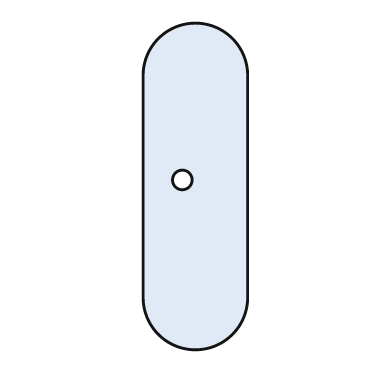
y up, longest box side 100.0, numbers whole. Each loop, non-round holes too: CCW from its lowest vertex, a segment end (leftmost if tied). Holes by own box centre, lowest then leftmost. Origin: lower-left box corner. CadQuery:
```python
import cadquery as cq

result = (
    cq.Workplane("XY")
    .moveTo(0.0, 16.0)
    .threePointArc((16.0, 0.0), (32.0, 16.0))
    .lineTo(32.0, 84.0)
    .threePointArc((16.0, 100.0), (0.0, 84.0))
    .close()
    .moveTo(12.0, 52.0)
    .circle(3.0)
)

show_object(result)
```